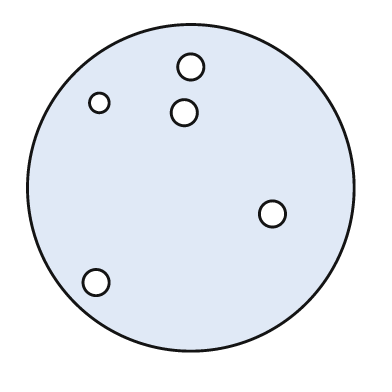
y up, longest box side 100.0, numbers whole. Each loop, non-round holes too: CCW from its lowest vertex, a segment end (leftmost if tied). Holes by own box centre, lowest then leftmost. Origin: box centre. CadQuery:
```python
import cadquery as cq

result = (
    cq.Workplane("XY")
    .moveTo(0.0, 0.0)
    .circle(50.0)
    .moveTo(-29.0, -29.0)
    .circle(4.0)
    .moveTo(25.0, -8.0)
    .circle(4.0)
    .moveTo(-2.0, 23.0)
    .circle(4.0)
    .moveTo(-28.0, 26.0)
    .circle(3.0)
    .moveTo(0.0, 37.0)
    .circle(4.0)
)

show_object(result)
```